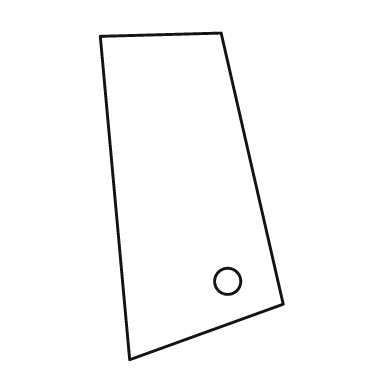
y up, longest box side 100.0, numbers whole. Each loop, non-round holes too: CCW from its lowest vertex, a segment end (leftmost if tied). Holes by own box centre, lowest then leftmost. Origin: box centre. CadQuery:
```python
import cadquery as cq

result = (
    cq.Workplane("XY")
    .moveTo(-19.0, -50.0)
    .lineTo(28.0, -33.0)
    .lineTo(9.0, 50.0)
    .lineTo(-28.0, 49.0)
    .close()
    .moveTo(11.0, -26.0)
    .circle(4.0)
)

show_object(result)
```